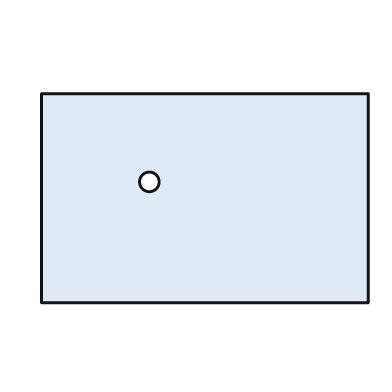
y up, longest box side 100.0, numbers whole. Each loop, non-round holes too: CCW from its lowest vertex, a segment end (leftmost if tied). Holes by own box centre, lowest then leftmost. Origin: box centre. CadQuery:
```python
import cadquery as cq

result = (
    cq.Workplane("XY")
    .moveTo(-50.0, -32.0)
    .lineTo(50.0, -32.0)
    .lineTo(50.0, 32.0)
    .lineTo(-50.0, 32.0)
    .close()
    .moveTo(-17.0, 5.0)
    .circle(3.0)
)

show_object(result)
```